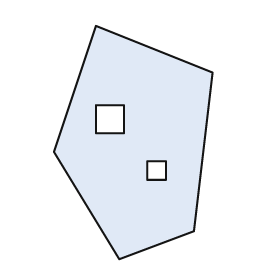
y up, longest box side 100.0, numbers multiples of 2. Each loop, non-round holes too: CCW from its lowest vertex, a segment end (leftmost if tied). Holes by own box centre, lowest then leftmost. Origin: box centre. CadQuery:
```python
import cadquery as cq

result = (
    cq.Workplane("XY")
    .moveTo(-6.0, -50.0)
    .lineTo(26.0, -38.0)
    .lineTo(34.0, 30.0)
    .lineTo(-16.0, 50.0)
    .lineTo(-34.0, -4.0)
    .close()
    .moveTo(6.0, -16.0)
    .lineTo(14.0, -16.0)
    .lineTo(14.0, -8.0)
    .lineTo(6.0, -8.0)
    .close()
    .moveTo(-16.0, 4.0)
    .lineTo(-4.0, 4.0)
    .lineTo(-4.0, 16.0)
    .lineTo(-16.0, 16.0)
    .close()
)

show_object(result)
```